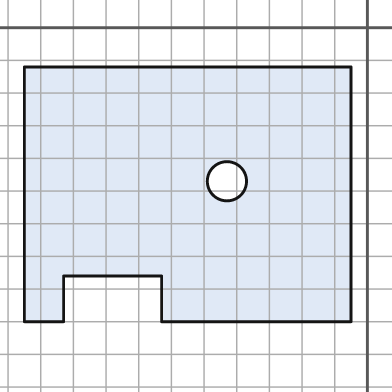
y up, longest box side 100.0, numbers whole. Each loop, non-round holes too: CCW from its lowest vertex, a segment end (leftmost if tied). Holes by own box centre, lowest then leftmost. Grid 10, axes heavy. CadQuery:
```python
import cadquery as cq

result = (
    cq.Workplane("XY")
    .moveTo(-105.0, -90.0)
    .lineTo(-93.0, -90.0)
    .lineTo(-93.0, -76.0)
    .lineTo(-63.0, -76.0)
    .lineTo(-63.0, -90.0)
    .lineTo(-5.0, -90.0)
    .lineTo(-5.0, -12.0)
    .lineTo(-105.0, -12.0)
    .close()
    .moveTo(-43.0, -47.0)
    .circle(6.0)
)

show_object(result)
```